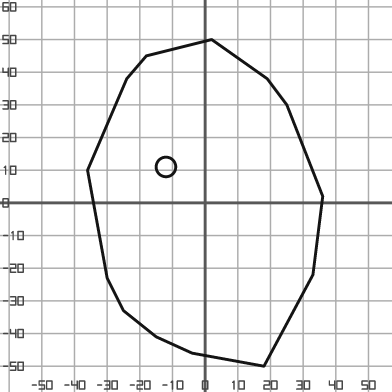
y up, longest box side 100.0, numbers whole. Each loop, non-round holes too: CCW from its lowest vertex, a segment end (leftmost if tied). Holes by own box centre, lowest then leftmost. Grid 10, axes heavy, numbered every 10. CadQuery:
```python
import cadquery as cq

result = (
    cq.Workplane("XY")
    .moveTo(18.0, -50.0)
    .lineTo(33.0, -22.0)
    .lineTo(36.0, 2.0)
    .lineTo(25.0, 30.0)
    .lineTo(19.0, 38.0)
    .lineTo(2.0, 50.0)
    .lineTo(-18.0, 45.0)
    .lineTo(-24.0, 38.0)
    .lineTo(-36.0, 10.0)
    .lineTo(-30.0, -23.0)
    .lineTo(-25.0, -33.0)
    .lineTo(-15.0, -41.0)
    .lineTo(-4.0, -46.0)
    .close()
    .moveTo(-12.0, 11.0)
    .circle(3.0)
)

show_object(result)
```